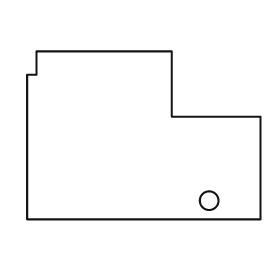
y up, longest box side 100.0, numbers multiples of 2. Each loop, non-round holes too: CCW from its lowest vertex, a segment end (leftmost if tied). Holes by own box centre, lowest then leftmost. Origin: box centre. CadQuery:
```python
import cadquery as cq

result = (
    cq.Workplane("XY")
    .moveTo(-50.0, -36.0)
    .lineTo(50.0, -36.0)
    .lineTo(50.0, 8.0)
    .lineTo(12.0, 8.0)
    .lineTo(12.0, 36.0)
    .lineTo(-46.0, 36.0)
    .lineTo(-46.0, 26.0)
    .lineTo(-50.0, 26.0)
    .close()
    .moveTo(28.0, -28.0)
    .circle(4.0)
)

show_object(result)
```